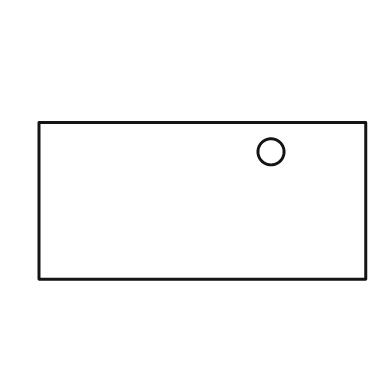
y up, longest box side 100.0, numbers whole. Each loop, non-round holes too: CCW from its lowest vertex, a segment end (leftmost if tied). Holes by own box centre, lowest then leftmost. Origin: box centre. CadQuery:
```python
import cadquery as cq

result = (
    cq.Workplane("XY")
    .moveTo(-50.0, -24.0)
    .lineTo(50.0, -24.0)
    .lineTo(50.0, 24.0)
    .lineTo(-50.0, 24.0)
    .close()
    .moveTo(21.0, 15.0)
    .circle(4.0)
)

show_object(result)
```